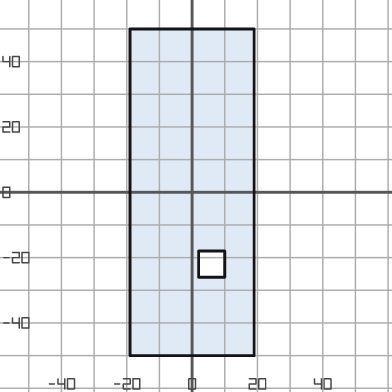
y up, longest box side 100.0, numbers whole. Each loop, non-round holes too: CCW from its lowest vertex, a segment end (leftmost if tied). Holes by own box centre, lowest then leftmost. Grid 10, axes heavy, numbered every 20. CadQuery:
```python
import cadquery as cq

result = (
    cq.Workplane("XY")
    .moveTo(-19.0, -50.0)
    .lineTo(19.0, -50.0)
    .lineTo(19.0, 50.0)
    .lineTo(-19.0, 50.0)
    .close()
    .moveTo(2.0, -26.0)
    .lineTo(10.0, -26.0)
    .lineTo(10.0, -18.0)
    .lineTo(2.0, -18.0)
    .close()
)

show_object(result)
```